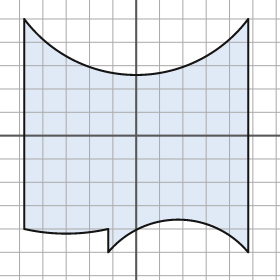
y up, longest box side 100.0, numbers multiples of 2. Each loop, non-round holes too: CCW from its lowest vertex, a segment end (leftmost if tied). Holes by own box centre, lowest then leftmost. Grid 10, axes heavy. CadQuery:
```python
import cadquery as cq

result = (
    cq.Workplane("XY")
    .moveTo(-12.0, -50.0)
    .threePointArc((18.0, -36.0), (48.0, -50.0))
    .lineTo(48.0, 50.0)
    .threePointArc((0.0, 26.0), (-48.0, 50.0))
    .lineTo(-48.0, -40.0)
    .threePointArc((-30.0, -42.0), (-12.0, -40.0))
    .close()
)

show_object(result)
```